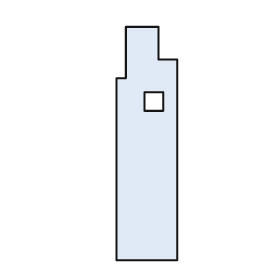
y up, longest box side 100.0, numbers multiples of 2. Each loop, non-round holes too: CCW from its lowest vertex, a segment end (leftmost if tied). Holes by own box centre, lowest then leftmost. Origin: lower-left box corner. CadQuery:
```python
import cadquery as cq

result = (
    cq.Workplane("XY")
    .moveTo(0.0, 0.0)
    .lineTo(26.0, 0.0)
    .lineTo(26.0, 86.0)
    .lineTo(18.0, 86.0)
    .lineTo(18.0, 100.0)
    .lineTo(4.0, 100.0)
    .lineTo(4.0, 78.0)
    .lineTo(0.0, 78.0)
    .close()
    .moveTo(12.0, 64.0)
    .lineTo(20.0, 64.0)
    .lineTo(20.0, 72.0)
    .lineTo(12.0, 72.0)
    .close()
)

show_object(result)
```